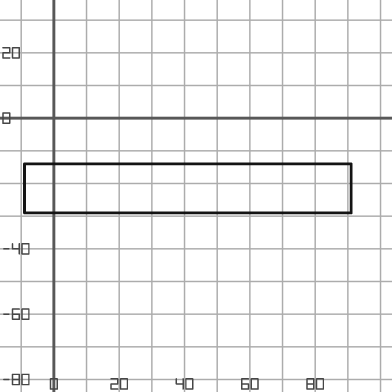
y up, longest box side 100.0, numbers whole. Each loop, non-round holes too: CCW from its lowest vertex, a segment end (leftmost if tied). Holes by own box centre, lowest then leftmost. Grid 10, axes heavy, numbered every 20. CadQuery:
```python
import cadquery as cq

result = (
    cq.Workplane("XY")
    .moveTo(-9.0, -29.0)
    .lineTo(91.0, -29.0)
    .lineTo(91.0, -14.0)
    .lineTo(-9.0, -14.0)
    .close()
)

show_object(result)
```